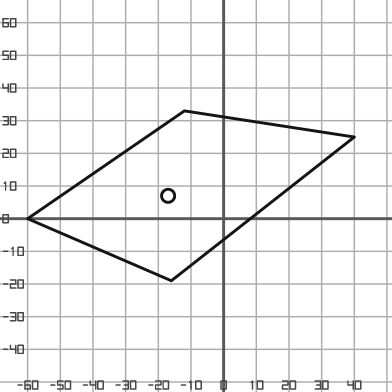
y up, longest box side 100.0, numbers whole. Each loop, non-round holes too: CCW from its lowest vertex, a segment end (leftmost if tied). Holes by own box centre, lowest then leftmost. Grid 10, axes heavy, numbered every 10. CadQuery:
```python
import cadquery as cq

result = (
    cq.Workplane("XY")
    .moveTo(-16.0, -19.0)
    .lineTo(40.0, 25.0)
    .lineTo(-12.0, 33.0)
    .lineTo(-60.0, 0.0)
    .close()
    .moveTo(-17.0, 7.0)
    .circle(2.0)
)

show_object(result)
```